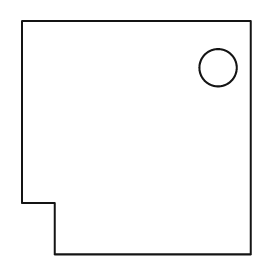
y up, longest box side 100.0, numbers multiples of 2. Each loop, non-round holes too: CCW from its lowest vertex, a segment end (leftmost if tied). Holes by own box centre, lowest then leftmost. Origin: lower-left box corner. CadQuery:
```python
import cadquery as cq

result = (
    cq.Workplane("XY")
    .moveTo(14.0, 0.0)
    .lineTo(98.0, 0.0)
    .lineTo(98.0, 100.0)
    .lineTo(0.0, 100.0)
    .lineTo(0.0, 22.0)
    .lineTo(14.0, 22.0)
    .close()
    .moveTo(84.0, 80.0)
    .circle(8.0)
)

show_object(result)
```